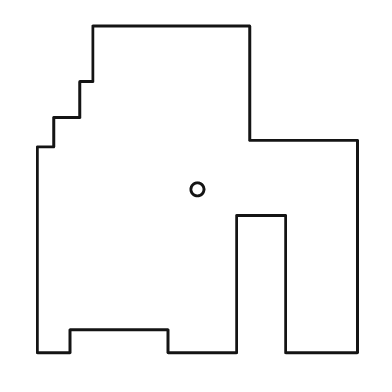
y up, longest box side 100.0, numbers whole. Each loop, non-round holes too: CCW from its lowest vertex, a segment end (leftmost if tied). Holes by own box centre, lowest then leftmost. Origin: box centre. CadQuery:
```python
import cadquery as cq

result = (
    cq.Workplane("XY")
    .moveTo(-49.0, -50.0)
    .lineTo(-39.0, -50.0)
    .lineTo(-39.0, -43.0)
    .lineTo(-9.0, -43.0)
    .lineTo(-9.0, -50.0)
    .lineTo(12.0, -50.0)
    .lineTo(12.0, -8.0)
    .lineTo(27.0, -8.0)
    .lineTo(27.0, -50.0)
    .lineTo(49.0, -50.0)
    .lineTo(49.0, 15.0)
    .lineTo(16.0, 15.0)
    .lineTo(16.0, 50.0)
    .lineTo(-32.0, 50.0)
    .lineTo(-32.0, 33.0)
    .lineTo(-36.0, 33.0)
    .lineTo(-36.0, 22.0)
    .lineTo(-44.0, 22.0)
    .lineTo(-44.0, 13.0)
    .lineTo(-49.0, 13.0)
    .close()
    .moveTo(0.0, 0.0)
    .circle(2.0)
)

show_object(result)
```